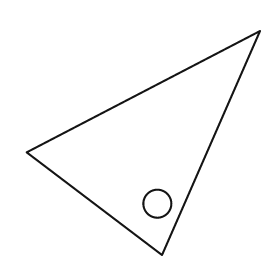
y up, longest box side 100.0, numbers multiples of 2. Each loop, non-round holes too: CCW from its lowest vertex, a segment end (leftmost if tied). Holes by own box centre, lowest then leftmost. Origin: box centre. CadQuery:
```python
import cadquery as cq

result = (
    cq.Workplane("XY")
    .moveTo(8.0, -48.0)
    .lineTo(50.0, 48.0)
    .lineTo(-50.0, -4.0)
    .close()
    .moveTo(6.0, -26.0)
    .circle(6.0)
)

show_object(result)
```